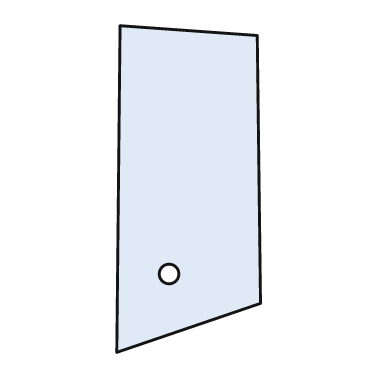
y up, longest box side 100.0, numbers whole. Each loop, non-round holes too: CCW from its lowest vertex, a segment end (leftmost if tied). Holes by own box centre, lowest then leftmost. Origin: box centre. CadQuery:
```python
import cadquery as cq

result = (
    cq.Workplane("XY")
    .moveTo(-22.0, -50.0)
    .lineTo(22.0, -35.0)
    .lineTo(21.0, 47.0)
    .lineTo(-21.0, 50.0)
    .close()
    .moveTo(-6.0, -26.0)
    .circle(3.0)
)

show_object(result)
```